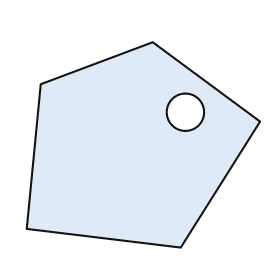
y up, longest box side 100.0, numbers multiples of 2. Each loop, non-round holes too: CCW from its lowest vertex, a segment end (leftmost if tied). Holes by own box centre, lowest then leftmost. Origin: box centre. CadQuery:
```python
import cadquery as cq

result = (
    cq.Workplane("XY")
    .moveTo(16.0, -44.0)
    .lineTo(50.0, 10.0)
    .lineTo(4.0, 44.0)
    .lineTo(-44.0, 26.0)
    .lineTo(-50.0, -36.0)
    .close()
    .moveTo(18.0, 14.0)
    .circle(8.0)
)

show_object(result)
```